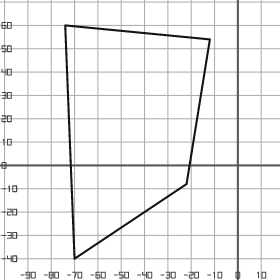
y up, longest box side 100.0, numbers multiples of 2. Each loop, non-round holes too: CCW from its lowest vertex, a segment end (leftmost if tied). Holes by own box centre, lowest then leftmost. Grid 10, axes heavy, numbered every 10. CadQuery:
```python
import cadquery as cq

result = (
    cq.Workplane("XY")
    .moveTo(-70.0, -40.0)
    .lineTo(-22.0, -8.0)
    .lineTo(-12.0, 54.0)
    .lineTo(-74.0, 60.0)
    .close()
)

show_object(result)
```